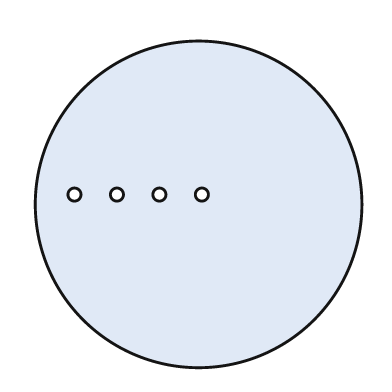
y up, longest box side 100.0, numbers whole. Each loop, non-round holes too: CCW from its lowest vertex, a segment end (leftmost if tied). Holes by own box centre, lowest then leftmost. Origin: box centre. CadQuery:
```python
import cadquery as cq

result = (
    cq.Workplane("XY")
    .moveTo(0.0, 0.0)
    .circle(50.0)
    .moveTo(-38.0, 3.0)
    .circle(2.0)
    .moveTo(-25.0, 3.0)
    .circle(2.0)
    .moveTo(-12.0, 3.0)
    .circle(2.0)
    .moveTo(1.0, 3.0)
    .circle(2.0)
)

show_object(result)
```